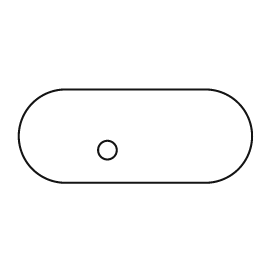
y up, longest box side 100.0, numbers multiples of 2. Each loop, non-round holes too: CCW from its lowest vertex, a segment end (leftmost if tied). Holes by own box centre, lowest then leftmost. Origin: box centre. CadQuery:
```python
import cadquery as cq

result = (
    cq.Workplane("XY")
    .moveTo(-30.0, -20.0)
    .lineTo(30.0, -20.0)
    .threePointArc((50.0, 0.0), (30.0, 20.0))
    .lineTo(-30.0, 20.0)
    .threePointArc((-50.0, 0.0), (-30.0, -20.0))
    .close()
    .moveTo(-12.0, -6.0)
    .circle(4.0)
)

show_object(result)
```